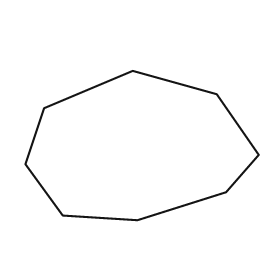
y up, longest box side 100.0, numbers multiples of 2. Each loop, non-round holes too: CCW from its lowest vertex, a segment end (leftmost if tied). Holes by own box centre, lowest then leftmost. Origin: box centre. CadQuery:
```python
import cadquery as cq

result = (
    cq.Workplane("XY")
    .moveTo(-2.0, -32.0)
    .lineTo(36.0, -20.0)
    .lineTo(50.0, -4.0)
    .lineTo(32.0, 22.0)
    .lineTo(-4.0, 32.0)
    .lineTo(-42.0, 16.0)
    .lineTo(-50.0, -8.0)
    .lineTo(-34.0, -30.0)
    .close()
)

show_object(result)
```